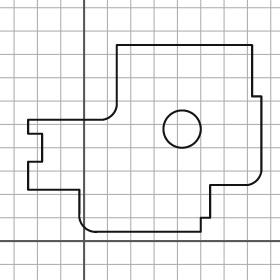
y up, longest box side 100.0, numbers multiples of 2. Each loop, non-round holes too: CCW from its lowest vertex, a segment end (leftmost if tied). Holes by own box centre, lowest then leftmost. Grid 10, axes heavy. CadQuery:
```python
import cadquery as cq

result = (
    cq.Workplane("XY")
    .moveTo(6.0, 4.0)
    .lineTo(50.0, 4.0)
    .lineTo(50.0, 10.0)
    .lineTo(54.0, 10.0)
    .lineTo(54.0, 24.0)
    .lineTo(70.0, 24.0)
    .threePointArc((74.0, 26.0), (76.0, 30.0))
    .lineTo(76.0, 62.0)
    .lineTo(72.0, 62.0)
    .lineTo(72.0, 84.0)
    .lineTo(14.0, 84.0)
    .lineTo(14.0, 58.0)
    .threePointArc((12.0, 54.0), (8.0, 52.0))
    .lineTo(-24.0, 52.0)
    .lineTo(-24.0, 46.0)
    .lineTo(-18.0, 46.0)
    .lineTo(-18.0, 34.0)
    .lineTo(-24.0, 34.0)
    .lineTo(-24.0, 22.0)
    .lineTo(-2.0, 22.0)
    .lineTo(-2.0, 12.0)
    .threePointArc((0.0, 6.0), (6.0, 4.0))
    .close()
    .moveTo(42.0, 48.0)
    .circle(8.0)
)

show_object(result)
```